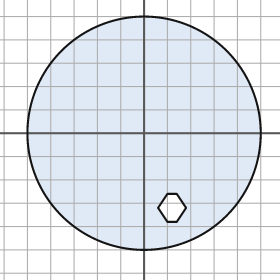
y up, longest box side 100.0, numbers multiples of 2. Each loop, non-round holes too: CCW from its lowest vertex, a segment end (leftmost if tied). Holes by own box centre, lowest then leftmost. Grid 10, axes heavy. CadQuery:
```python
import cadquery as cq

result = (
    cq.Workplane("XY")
    .moveTo(0.0, 0.0)
    .circle(50.0)
    .moveTo(10.0, -38.0)
    .lineTo(14.0, -38.0)
    .lineTo(18.0, -32.0)
    .lineTo(14.0, -26.0)
    .lineTo(10.0, -26.0)
    .lineTo(6.0, -32.0)
    .close()
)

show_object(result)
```